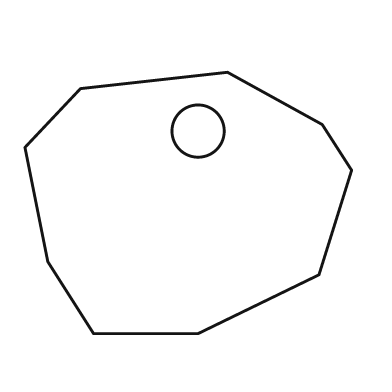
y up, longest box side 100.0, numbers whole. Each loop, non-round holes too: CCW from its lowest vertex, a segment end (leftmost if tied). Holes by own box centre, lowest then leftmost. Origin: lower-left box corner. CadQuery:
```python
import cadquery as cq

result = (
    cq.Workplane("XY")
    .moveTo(21.0, 0.0)
    .lineTo(53.0, 0.0)
    .lineTo(90.0, 18.0)
    .lineTo(100.0, 50.0)
    .lineTo(91.0, 64.0)
    .lineTo(62.0, 80.0)
    .lineTo(17.0, 75.0)
    .lineTo(0.0, 57.0)
    .lineTo(7.0, 22.0)
    .close()
    .moveTo(53.0, 62.0)
    .circle(8.0)
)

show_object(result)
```